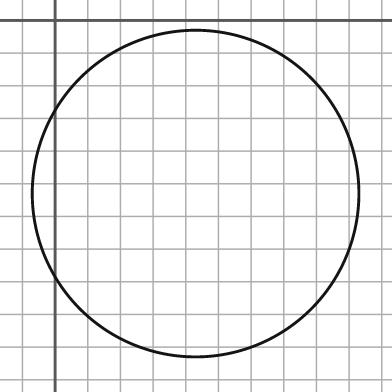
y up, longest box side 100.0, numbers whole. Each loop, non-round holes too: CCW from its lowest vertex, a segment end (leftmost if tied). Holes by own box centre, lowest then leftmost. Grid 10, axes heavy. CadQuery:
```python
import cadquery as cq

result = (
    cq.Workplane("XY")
    .moveTo(43.0, -53.0)
    .circle(50.0)
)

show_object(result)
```